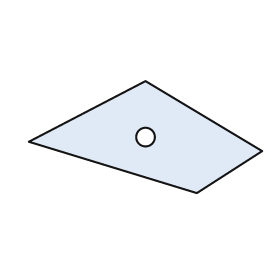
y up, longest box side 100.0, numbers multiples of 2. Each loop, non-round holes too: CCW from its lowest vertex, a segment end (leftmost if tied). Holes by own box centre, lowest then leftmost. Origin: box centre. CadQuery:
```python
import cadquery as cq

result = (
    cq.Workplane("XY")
    .moveTo(22.0, -24.0)
    .lineTo(50.0, -6.0)
    .lineTo(0.0, 24.0)
    .lineTo(-50.0, -2.0)
    .close()
    .moveTo(0.0, 0.0)
    .circle(4.0)
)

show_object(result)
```